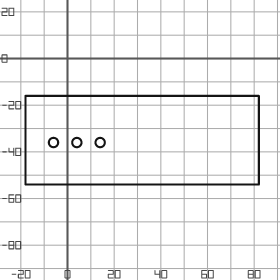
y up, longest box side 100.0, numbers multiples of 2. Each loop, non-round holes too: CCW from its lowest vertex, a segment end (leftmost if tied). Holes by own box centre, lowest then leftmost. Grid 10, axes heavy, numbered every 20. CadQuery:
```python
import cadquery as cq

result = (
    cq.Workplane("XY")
    .moveTo(-18.0, -54.0)
    .lineTo(82.0, -54.0)
    .lineTo(82.0, -16.0)
    .lineTo(-18.0, -16.0)
    .close()
    .moveTo(-6.0, -36.0)
    .circle(2.0)
    .moveTo(4.0, -36.0)
    .circle(2.0)
    .moveTo(14.0, -36.0)
    .circle(2.0)
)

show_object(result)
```